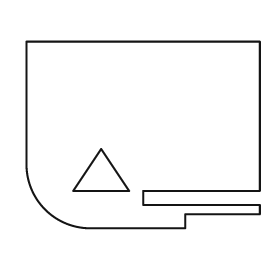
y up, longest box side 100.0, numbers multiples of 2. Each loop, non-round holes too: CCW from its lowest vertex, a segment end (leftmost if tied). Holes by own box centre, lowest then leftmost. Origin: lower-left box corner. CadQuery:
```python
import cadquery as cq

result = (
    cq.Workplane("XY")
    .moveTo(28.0, 0.0)
    .lineTo(68.0, 0.0)
    .lineTo(68.0, 6.0)
    .lineTo(100.0, 6.0)
    .lineTo(100.0, 10.0)
    .lineTo(50.0, 10.0)
    .lineTo(50.0, 16.0)
    .lineTo(100.0, 16.0)
    .lineTo(100.0, 80.0)
    .lineTo(0.0, 80.0)
    .lineTo(0.0, 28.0)
    .threePointArc((8.0, 8.0), (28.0, 0.0))
    .close()
    .moveTo(20.0, 16.0)
    .lineTo(44.0, 16.0)
    .lineTo(32.0, 34.0)
    .close()
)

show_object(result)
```